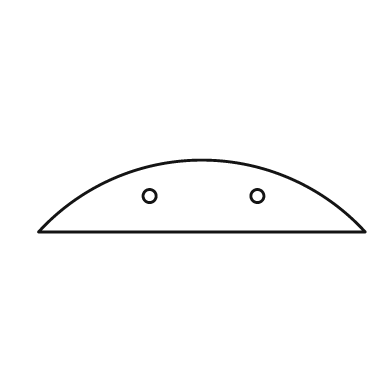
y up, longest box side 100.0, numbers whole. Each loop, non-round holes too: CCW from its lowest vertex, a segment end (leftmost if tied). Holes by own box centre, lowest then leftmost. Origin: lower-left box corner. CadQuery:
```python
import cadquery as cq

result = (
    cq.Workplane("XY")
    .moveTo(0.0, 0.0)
    .lineTo(100.0, 0.0)
    .threePointArc((50.0, 22.0), (0.0, 0.0))
    .close()
    .moveTo(34.0, 11.0)
    .circle(2.0)
    .moveTo(67.0, 11.0)
    .circle(2.0)
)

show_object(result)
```